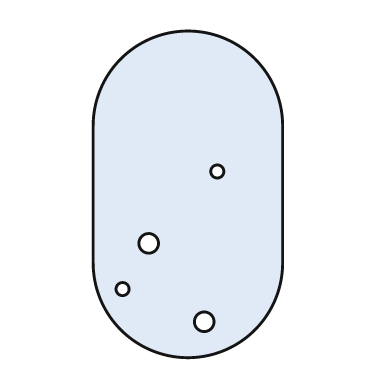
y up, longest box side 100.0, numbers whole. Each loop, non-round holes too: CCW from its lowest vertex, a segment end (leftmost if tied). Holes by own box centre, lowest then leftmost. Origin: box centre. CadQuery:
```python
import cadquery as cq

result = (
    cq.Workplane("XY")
    .moveTo(-29.0, -21.0)
    .threePointArc((0.0, -50.0), (29.0, -21.0))
    .lineTo(29.0, 21.0)
    .threePointArc((0.0, 50.0), (-29.0, 21.0))
    .close()
    .moveTo(5.0, -39.0)
    .circle(3.0)
    .moveTo(-20.0, -29.0)
    .circle(2.0)
    .moveTo(-12.0, -15.0)
    .circle(3.0)
    .moveTo(9.0, 7.0)
    .circle(2.0)
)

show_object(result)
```